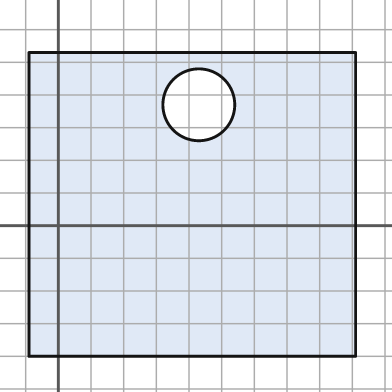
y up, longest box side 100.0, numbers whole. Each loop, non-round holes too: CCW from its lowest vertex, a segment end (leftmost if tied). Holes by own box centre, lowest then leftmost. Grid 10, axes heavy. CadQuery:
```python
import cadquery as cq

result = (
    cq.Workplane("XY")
    .moveTo(-9.0, -40.0)
    .lineTo(91.0, -40.0)
    .lineTo(91.0, 53.0)
    .lineTo(-9.0, 53.0)
    .close()
    .moveTo(43.0, 37.0)
    .circle(11.0)
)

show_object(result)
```